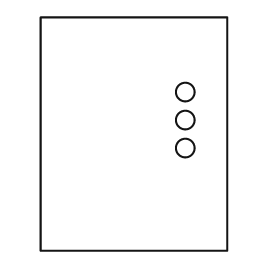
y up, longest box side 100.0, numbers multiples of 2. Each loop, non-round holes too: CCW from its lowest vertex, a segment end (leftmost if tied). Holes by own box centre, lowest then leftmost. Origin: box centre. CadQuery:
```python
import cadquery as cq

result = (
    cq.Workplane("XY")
    .moveTo(-40.0, -50.0)
    .lineTo(40.0, -50.0)
    .lineTo(40.0, 50.0)
    .lineTo(-40.0, 50.0)
    .close()
    .moveTo(22.0, -6.0)
    .circle(4.0)
    .moveTo(22.0, 6.0)
    .circle(4.0)
    .moveTo(22.0, 18.0)
    .circle(4.0)
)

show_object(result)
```